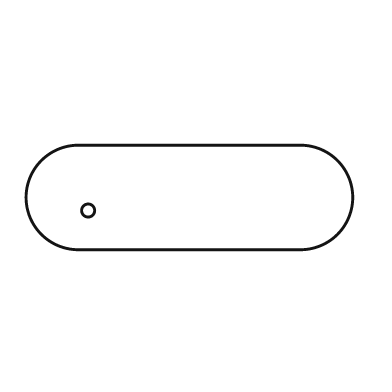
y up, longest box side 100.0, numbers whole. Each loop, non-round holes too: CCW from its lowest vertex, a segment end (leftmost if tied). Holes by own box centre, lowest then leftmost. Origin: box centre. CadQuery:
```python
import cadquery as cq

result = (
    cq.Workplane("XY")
    .moveTo(-34.0, -16.0)
    .lineTo(34.0, -16.0)
    .threePointArc((50.0, 0.0), (34.0, 16.0))
    .lineTo(-34.0, 16.0)
    .threePointArc((-50.0, 0.0), (-34.0, -16.0))
    .close()
    .moveTo(-31.0, -4.0)
    .circle(2.0)
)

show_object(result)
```